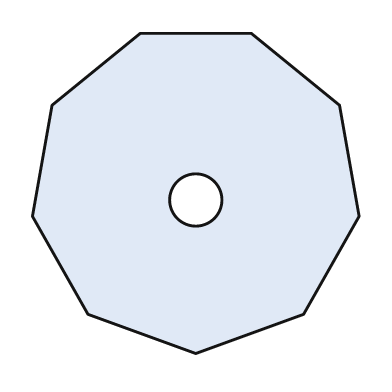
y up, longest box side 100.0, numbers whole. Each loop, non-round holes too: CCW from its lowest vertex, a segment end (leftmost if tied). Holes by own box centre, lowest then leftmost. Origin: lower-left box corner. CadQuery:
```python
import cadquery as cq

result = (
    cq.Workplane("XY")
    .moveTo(50.0, 0.0)
    .lineTo(83.0, 12.0)
    .lineTo(100.0, 42.0)
    .lineTo(94.0, 76.0)
    .lineTo(67.0, 98.0)
    .lineTo(33.0, 98.0)
    .lineTo(6.0, 76.0)
    .lineTo(0.0, 42.0)
    .lineTo(17.0, 12.0)
    .close()
    .moveTo(50.0, 47.0)
    .circle(8.0)
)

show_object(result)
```